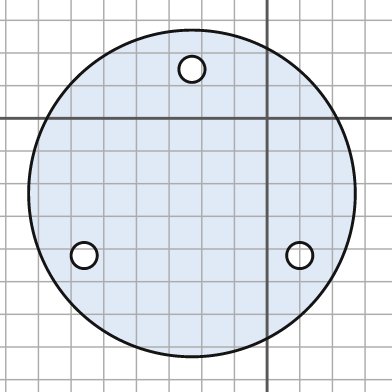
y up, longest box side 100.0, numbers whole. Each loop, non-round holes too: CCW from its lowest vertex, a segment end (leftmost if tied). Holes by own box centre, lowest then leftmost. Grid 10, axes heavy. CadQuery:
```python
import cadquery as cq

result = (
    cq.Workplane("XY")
    .moveTo(-23.0, -23.0)
    .circle(50.0)
    .moveTo(-56.0, -42.0)
    .circle(4.0)
    .moveTo(10.0, -42.0)
    .circle(4.0)
    .moveTo(-23.0, 15.0)
    .circle(4.0)
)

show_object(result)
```